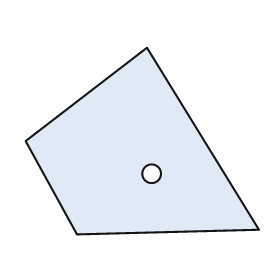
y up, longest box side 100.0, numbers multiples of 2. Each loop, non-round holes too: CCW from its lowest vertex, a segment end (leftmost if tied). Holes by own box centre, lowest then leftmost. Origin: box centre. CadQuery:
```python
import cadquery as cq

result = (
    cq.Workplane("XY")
    .moveTo(-28.0, -40.0)
    .lineTo(50.0, -38.0)
    .lineTo(2.0, 40.0)
    .lineTo(-50.0, 0.0)
    .close()
    .moveTo(4.0, -14.0)
    .circle(4.0)
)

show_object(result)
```